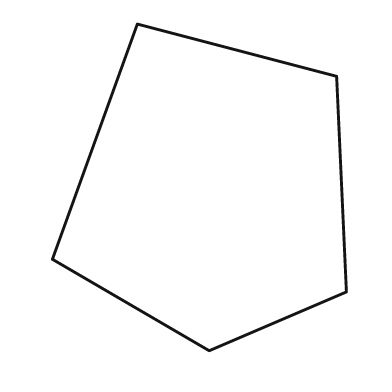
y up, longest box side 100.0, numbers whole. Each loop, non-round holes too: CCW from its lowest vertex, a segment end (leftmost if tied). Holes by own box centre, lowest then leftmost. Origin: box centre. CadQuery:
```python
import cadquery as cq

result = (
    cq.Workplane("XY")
    .moveTo(3.0, -50.0)
    .lineTo(45.0, -32.0)
    .lineTo(42.0, 34.0)
    .lineTo(-19.0, 50.0)
    .lineTo(-45.0, -22.0)
    .close()
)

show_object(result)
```